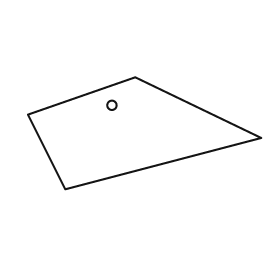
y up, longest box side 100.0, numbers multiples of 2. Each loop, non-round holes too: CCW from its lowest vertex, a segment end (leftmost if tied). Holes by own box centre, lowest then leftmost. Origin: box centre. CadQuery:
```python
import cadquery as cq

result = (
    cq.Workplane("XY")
    .moveTo(-34.0, -24.0)
    .lineTo(50.0, -2.0)
    .lineTo(-4.0, 24.0)
    .lineTo(-50.0, 8.0)
    .close()
    .moveTo(-14.0, 12.0)
    .circle(2.0)
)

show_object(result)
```